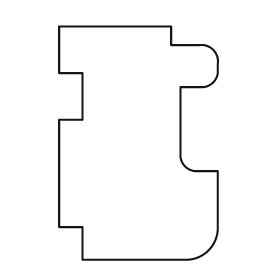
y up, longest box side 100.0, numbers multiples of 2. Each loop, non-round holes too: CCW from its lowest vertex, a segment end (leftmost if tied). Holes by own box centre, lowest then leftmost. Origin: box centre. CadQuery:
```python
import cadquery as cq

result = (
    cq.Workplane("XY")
    .moveTo(-24.0, -50.0)
    .lineTo(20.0, -50.0)
    .threePointArc((30.0, -46.0), (34.0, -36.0))
    .lineTo(34.0, -12.0)
    .lineTo(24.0, -12.0)
    .threePointArc((20.0, -10.0), (18.0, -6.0))
    .lineTo(18.0, 24.0)
    .lineTo(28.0, 24.0)
    .threePointArc((32.0, 26.0), (34.0, 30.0))
    .lineTo(34.0, 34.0)
    .threePointArc((32.0, 40.0), (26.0, 42.0))
    .lineTo(14.0, 42.0)
    .lineTo(14.0, 50.0)
    .lineTo(-34.0, 50.0)
    .lineTo(-34.0, 30.0)
    .lineTo(-24.0, 30.0)
    .lineTo(-24.0, 10.0)
    .lineTo(-34.0, 10.0)
    .lineTo(-34.0, -36.0)
    .lineTo(-24.0, -36.0)
    .close()
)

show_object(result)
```